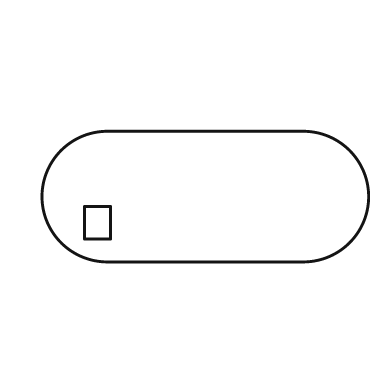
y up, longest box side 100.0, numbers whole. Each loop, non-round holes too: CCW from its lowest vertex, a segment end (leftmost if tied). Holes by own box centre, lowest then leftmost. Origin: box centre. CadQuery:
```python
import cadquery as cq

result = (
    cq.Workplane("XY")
    .moveTo(-30.0, -20.0)
    .lineTo(30.0, -20.0)
    .threePointArc((50.0, 0.0), (30.0, 20.0))
    .lineTo(-30.0, 20.0)
    .threePointArc((-50.0, 0.0), (-30.0, -20.0))
    .close()
    .moveTo(-37.0, -13.0)
    .lineTo(-29.0, -13.0)
    .lineTo(-29.0, -3.0)
    .lineTo(-37.0, -3.0)
    .close()
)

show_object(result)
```